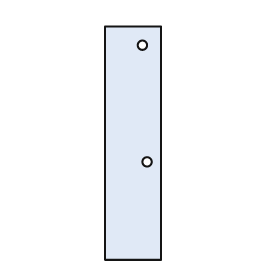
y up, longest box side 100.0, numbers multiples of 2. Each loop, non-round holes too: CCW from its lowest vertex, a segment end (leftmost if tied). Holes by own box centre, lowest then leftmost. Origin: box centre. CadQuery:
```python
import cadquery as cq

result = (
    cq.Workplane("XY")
    .moveTo(-12.0, -50.0)
    .lineTo(12.0, -50.0)
    .lineTo(12.0, 50.0)
    .lineTo(-12.0, 50.0)
    .close()
    .moveTo(6.0, -8.0)
    .circle(2.0)
    .moveTo(4.0, 42.0)
    .circle(2.0)
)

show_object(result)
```